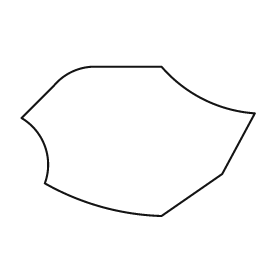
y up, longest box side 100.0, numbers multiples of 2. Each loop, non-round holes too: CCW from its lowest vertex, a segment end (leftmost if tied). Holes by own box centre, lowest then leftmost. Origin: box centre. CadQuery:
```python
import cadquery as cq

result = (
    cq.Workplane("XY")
    .moveTo(10.0, -32.0)
    .lineTo(36.0, -14.0)
    .lineTo(50.0, 12.0)
    .threePointArc((28.0, 18.0), (10.0, 32.0))
    .lineTo(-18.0, 32.0)
    .threePointArc((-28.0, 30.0), (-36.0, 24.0))
    .lineTo(-50.0, 10.0)
    .threePointArc((-40.0, -2.0), (-40.0, -18.0))
    .threePointArc((-16.0, -28.0), (10.0, -32.0))
    .close()
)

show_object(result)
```